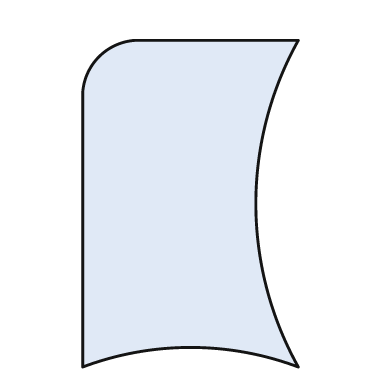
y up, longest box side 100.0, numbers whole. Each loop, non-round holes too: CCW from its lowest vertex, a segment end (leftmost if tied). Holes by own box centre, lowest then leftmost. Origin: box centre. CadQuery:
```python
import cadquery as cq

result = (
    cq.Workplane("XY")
    .moveTo(-33.0, -50.0)
    .threePointArc((0.0, -44.0), (33.0, -50.0))
    .threePointArc((20.0, 0.0), (33.0, 50.0))
    .lineTo(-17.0, 50.0)
    .threePointArc((-28.0, 45.0), (-33.0, 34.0))
    .close()
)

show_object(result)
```